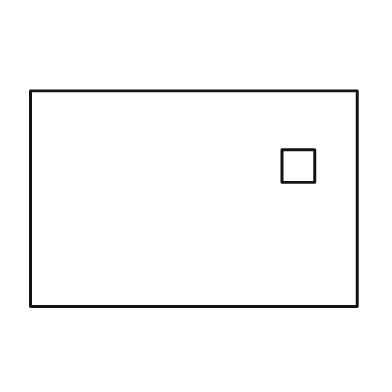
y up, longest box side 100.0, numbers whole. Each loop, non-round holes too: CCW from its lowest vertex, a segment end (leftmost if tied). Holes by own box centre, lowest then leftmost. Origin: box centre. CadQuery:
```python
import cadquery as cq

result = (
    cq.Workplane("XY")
    .moveTo(-50.0, -33.0)
    .lineTo(50.0, -33.0)
    .lineTo(50.0, 33.0)
    .lineTo(-50.0, 33.0)
    .close()
    .moveTo(27.0, 5.0)
    .lineTo(37.0, 5.0)
    .lineTo(37.0, 15.0)
    .lineTo(27.0, 15.0)
    .close()
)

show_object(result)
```